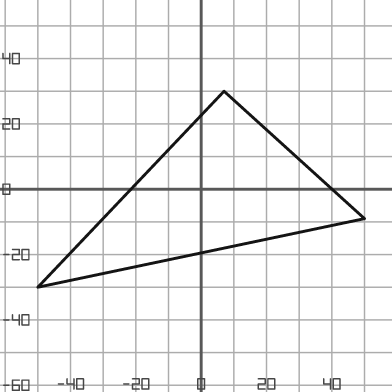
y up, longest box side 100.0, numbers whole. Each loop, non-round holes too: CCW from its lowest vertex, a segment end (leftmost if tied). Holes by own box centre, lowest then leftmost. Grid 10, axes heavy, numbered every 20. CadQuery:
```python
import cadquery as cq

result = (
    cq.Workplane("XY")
    .moveTo(-50.0, -30.0)
    .lineTo(50.0, -9.0)
    .lineTo(7.0, 30.0)
    .close()
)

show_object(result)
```